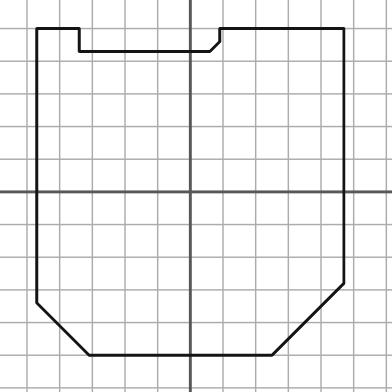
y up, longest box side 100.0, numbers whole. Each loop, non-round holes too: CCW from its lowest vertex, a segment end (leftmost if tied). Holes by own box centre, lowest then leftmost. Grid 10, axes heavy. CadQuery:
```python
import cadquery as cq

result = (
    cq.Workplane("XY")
    .moveTo(-31.0, -50.0)
    .lineTo(25.0, -50.0)
    .lineTo(47.0, -28.0)
    .lineTo(47.0, 50.0)
    .lineTo(9.0, 50.0)
    .lineTo(9.0, 46.0)
    .lineTo(6.0, 43.0)
    .lineTo(-34.0, 43.0)
    .lineTo(-34.0, 50.0)
    .lineTo(-47.0, 50.0)
    .lineTo(-47.0, -34.0)
    .close()
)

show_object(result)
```